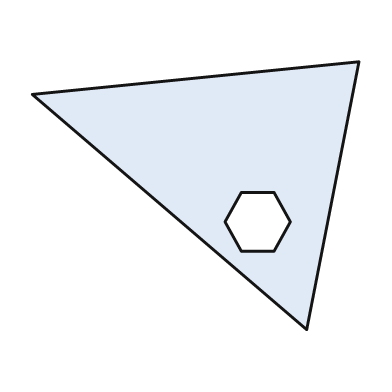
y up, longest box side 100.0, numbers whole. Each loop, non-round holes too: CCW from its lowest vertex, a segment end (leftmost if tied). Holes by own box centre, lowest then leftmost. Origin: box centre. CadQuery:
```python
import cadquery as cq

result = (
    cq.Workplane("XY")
    .moveTo(34.0, -41.0)
    .lineTo(50.0, 41.0)
    .lineTo(-50.0, 31.0)
    .close()
    .moveTo(14.0, -17.0)
    .lineTo(24.0, -17.0)
    .lineTo(29.0, -8.0)
    .lineTo(24.0, 1.0)
    .lineTo(14.0, 1.0)
    .lineTo(9.0, -8.0)
    .close()
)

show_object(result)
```